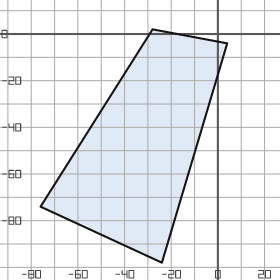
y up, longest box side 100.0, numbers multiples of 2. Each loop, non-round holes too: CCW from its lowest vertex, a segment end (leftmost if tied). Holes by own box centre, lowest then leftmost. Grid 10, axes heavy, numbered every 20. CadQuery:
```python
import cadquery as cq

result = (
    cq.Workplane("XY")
    .moveTo(-24.0, -98.0)
    .lineTo(4.0, -4.0)
    .lineTo(-28.0, 2.0)
    .lineTo(-76.0, -74.0)
    .close()
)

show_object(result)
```